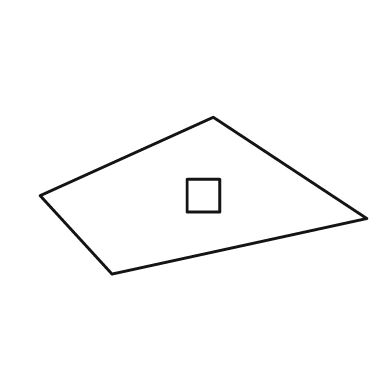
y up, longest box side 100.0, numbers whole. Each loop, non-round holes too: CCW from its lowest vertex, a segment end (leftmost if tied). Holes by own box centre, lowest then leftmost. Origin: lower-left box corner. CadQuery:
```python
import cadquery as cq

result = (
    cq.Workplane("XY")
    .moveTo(22.0, 0.0)
    .lineTo(100.0, 17.0)
    .lineTo(53.0, 48.0)
    .lineTo(0.0, 24.0)
    .close()
    .moveTo(45.0, 19.0)
    .lineTo(55.0, 19.0)
    .lineTo(55.0, 29.0)
    .lineTo(45.0, 29.0)
    .close()
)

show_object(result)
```